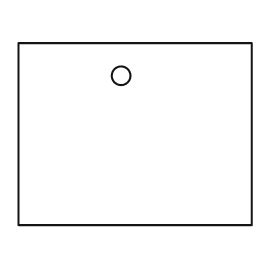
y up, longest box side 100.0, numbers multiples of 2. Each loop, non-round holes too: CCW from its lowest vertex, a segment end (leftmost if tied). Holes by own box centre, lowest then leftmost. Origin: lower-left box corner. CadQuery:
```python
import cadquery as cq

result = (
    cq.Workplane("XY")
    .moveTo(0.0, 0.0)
    .lineTo(100.0, 0.0)
    .lineTo(100.0, 78.0)
    .lineTo(0.0, 78.0)
    .close()
    .moveTo(44.0, 64.0)
    .circle(4.0)
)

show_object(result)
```